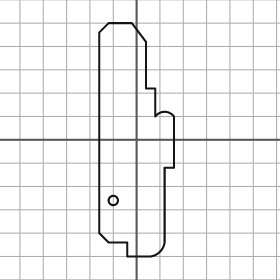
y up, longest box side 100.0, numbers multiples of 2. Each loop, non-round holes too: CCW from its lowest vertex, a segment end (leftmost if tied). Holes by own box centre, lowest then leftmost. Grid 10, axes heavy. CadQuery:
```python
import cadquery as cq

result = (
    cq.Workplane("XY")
    .moveTo(-4.0, -50.0)
    .lineTo(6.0, -50.0)
    .threePointArc((10.0, -48.0), (12.0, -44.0))
    .lineTo(12.0, -12.0)
    .lineTo(16.0, -12.0)
    .lineTo(16.0, 10.0)
    .threePointArc((12.0, 12.0), (8.0, 10.0))
    .lineTo(8.0, 22.0)
    .lineTo(4.0, 22.0)
    .lineTo(4.0, 42.0)
    .lineTo(-2.0, 50.0)
    .lineTo(-12.0, 50.0)
    .lineTo(-16.0, 46.0)
    .lineTo(-16.0, -40.0)
    .lineTo(-12.0, -44.0)
    .lineTo(-4.0, -44.0)
    .close()
    .moveTo(-10.0, -26.0)
    .circle(2.0)
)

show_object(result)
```